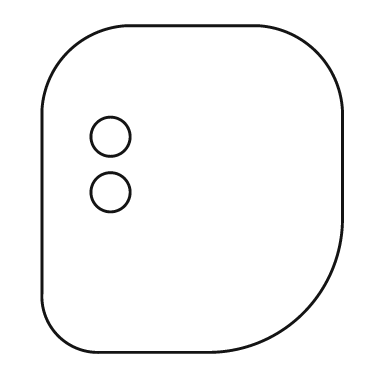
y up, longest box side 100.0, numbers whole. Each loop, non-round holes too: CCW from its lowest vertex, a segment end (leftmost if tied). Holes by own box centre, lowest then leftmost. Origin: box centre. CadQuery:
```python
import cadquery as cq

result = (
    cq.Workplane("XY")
    .moveTo(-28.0, -50.0)
    .lineTo(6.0, -50.0)
    .threePointArc((34.0, -38.0), (46.0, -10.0))
    .lineTo(46.0, 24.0)
    .threePointArc((38.0, 42.0), (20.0, 50.0))
    .lineTo(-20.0, 50.0)
    .threePointArc((-38.0, 42.0), (-46.0, 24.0))
    .lineTo(-46.0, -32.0)
    .threePointArc((-41.0, -45.0), (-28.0, -50.0))
    .close()
    .moveTo(-25.0, -1.0)
    .circle(6.0)
    .moveTo(-25.0, 16.0)
    .circle(6.0)
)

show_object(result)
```